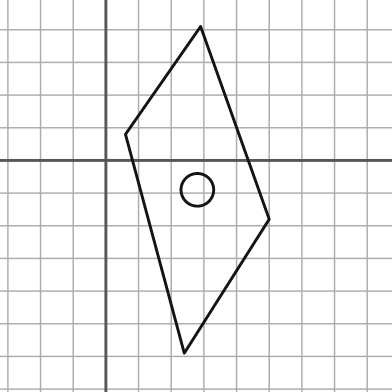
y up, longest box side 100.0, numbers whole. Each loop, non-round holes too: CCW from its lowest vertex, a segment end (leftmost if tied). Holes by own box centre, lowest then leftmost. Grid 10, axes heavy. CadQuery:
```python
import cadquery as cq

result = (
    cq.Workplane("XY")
    .moveTo(24.0, -59.0)
    .lineTo(50.0, -18.0)
    .lineTo(29.0, 41.0)
    .lineTo(6.0, 8.0)
    .close()
    .moveTo(28.0, -9.0)
    .circle(5.0)
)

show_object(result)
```